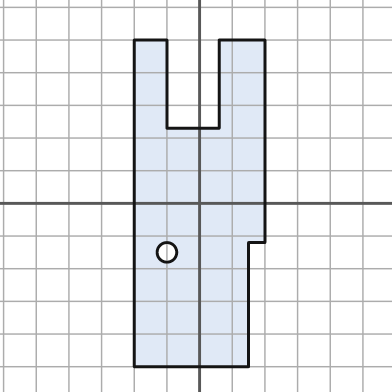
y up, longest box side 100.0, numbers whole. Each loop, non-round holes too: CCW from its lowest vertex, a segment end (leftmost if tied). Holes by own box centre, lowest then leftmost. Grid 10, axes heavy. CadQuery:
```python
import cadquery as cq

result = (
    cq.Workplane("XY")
    .moveTo(-20.0, -50.0)
    .lineTo(15.0, -50.0)
    .lineTo(15.0, -12.0)
    .lineTo(20.0, -12.0)
    .lineTo(20.0, 50.0)
    .lineTo(6.0, 50.0)
    .lineTo(6.0, 23.0)
    .lineTo(-10.0, 23.0)
    .lineTo(-10.0, 50.0)
    .lineTo(-20.0, 50.0)
    .close()
    .moveTo(-10.0, -15.0)
    .circle(3.0)
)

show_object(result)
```